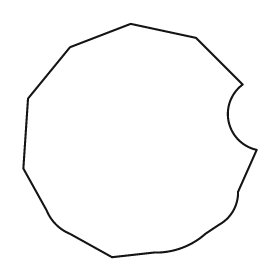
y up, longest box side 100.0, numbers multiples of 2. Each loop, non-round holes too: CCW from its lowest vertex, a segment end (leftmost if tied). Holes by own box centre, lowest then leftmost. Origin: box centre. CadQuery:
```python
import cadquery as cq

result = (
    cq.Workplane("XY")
    .moveTo(-12.0, -50.0)
    .lineTo(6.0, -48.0)
    .threePointArc((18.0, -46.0), (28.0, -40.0))
    .lineTo(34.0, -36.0)
    .threePointArc((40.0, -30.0), (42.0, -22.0))
    .lineTo(50.0, -4.0)
    .threePointArc((38.0, 8.0), (44.0, 24.0))
    .lineTo(24.0, 44.0)
    .lineTo(-4.0, 50.0)
    .lineTo(-30.0, 40.0)
    .lineTo(-48.0, 18.0)
    .lineTo(-50.0, -12.0)
    .lineTo(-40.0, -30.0)
    .threePointArc((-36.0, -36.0), (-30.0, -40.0))
    .close()
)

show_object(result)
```